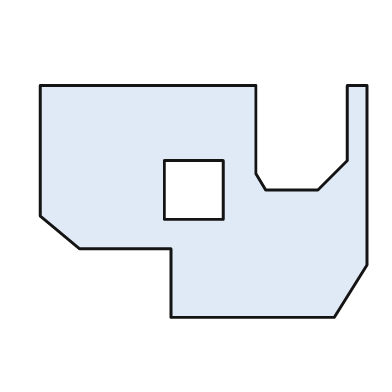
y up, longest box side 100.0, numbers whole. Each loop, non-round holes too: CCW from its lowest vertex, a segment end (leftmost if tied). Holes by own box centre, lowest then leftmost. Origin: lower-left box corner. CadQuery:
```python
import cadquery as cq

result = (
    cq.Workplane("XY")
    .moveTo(40.0, 0.0)
    .lineTo(90.0, 0.0)
    .lineTo(100.0, 16.0)
    .lineTo(100.0, 71.0)
    .lineTo(94.0, 71.0)
    .lineTo(94.0, 48.0)
    .lineTo(85.0, 39.0)
    .lineTo(69.0, 39.0)
    .lineTo(66.0, 44.0)
    .lineTo(66.0, 71.0)
    .lineTo(0.0, 71.0)
    .lineTo(0.0, 31.0)
    .lineTo(12.0, 21.0)
    .lineTo(40.0, 21.0)
    .close()
    .moveTo(38.0, 30.0)
    .lineTo(56.0, 30.0)
    .lineTo(56.0, 48.0)
    .lineTo(38.0, 48.0)
    .close()
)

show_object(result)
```